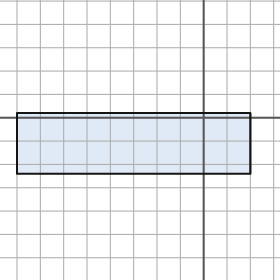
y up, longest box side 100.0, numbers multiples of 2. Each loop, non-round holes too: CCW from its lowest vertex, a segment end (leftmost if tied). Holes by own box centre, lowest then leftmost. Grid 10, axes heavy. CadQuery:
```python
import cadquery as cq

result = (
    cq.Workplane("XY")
    .moveTo(-80.0, -24.0)
    .lineTo(20.0, -24.0)
    .lineTo(20.0, 2.0)
    .lineTo(-80.0, 2.0)
    .close()
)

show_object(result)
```